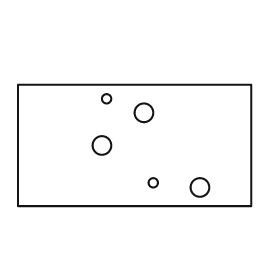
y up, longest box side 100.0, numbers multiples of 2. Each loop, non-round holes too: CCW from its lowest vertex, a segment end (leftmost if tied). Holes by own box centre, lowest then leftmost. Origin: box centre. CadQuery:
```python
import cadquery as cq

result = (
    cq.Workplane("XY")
    .moveTo(-50.0, -26.0)
    .lineTo(50.0, -26.0)
    .lineTo(50.0, 26.0)
    .lineTo(-50.0, 26.0)
    .close()
    .moveTo(28.0, -18.0)
    .circle(4.0)
    .moveTo(8.0, -16.0)
    .circle(2.0)
    .moveTo(-14.0, 0.0)
    .circle(4.0)
    .moveTo(4.0, 14.0)
    .circle(4.0)
    .moveTo(-12.0, 20.0)
    .circle(2.0)
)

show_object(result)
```